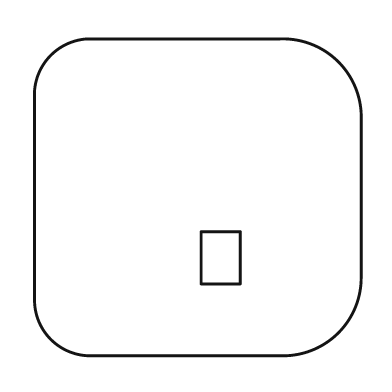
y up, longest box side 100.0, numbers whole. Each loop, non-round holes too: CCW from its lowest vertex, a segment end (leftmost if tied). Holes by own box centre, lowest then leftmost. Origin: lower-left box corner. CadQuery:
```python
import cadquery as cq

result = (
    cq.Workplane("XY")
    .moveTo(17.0, 0.0)
    .lineTo(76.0, 0.0)
    .threePointArc((93.0, 7.0), (100.0, 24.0))
    .lineTo(100.0, 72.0)
    .threePointArc((93.0, 90.0), (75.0, 97.0))
    .lineTo(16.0, 97.0)
    .threePointArc((5.0, 92.0), (0.0, 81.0))
    .lineTo(0.0, 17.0)
    .threePointArc((5.0, 5.0), (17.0, 0.0))
    .close()
    .moveTo(51.0, 22.0)
    .lineTo(63.0, 22.0)
    .lineTo(63.0, 38.0)
    .lineTo(51.0, 38.0)
    .close()
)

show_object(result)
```